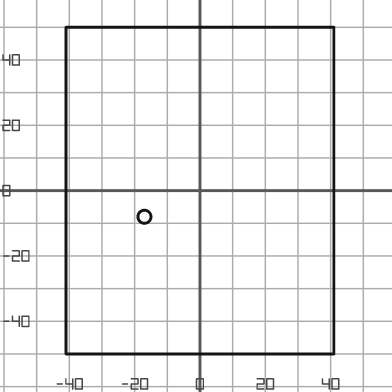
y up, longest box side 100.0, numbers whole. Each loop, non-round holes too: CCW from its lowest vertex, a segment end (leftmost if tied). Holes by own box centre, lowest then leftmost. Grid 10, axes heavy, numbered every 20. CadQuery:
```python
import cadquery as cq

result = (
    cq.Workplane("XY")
    .moveTo(-41.0, -50.0)
    .lineTo(41.0, -50.0)
    .lineTo(41.0, 50.0)
    .lineTo(-41.0, 50.0)
    .close()
    .moveTo(-17.0, -8.0)
    .circle(2.0)
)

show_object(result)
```